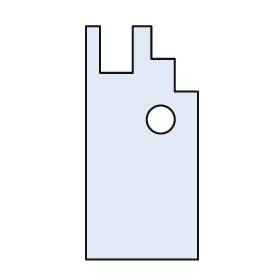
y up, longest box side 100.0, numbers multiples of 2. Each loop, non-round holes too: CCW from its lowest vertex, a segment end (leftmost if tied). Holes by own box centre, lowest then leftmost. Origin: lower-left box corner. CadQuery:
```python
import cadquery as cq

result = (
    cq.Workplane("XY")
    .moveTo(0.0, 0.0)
    .lineTo(48.0, 0.0)
    .lineTo(48.0, 72.0)
    .lineTo(38.0, 72.0)
    .lineTo(38.0, 86.0)
    .lineTo(28.0, 86.0)
    .lineTo(28.0, 100.0)
    .lineTo(20.0, 100.0)
    .lineTo(20.0, 80.0)
    .lineTo(6.0, 80.0)
    .lineTo(6.0, 100.0)
    .lineTo(0.0, 100.0)
    .close()
    .moveTo(32.0, 60.0)
    .circle(6.0)
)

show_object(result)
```